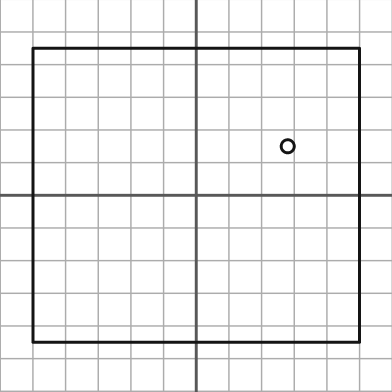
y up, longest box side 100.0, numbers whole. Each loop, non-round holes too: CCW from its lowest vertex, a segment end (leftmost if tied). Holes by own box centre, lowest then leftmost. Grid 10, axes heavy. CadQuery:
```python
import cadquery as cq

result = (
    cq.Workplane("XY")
    .moveTo(-50.0, -45.0)
    .lineTo(50.0, -45.0)
    .lineTo(50.0, 45.0)
    .lineTo(-50.0, 45.0)
    .close()
    .moveTo(28.0, 15.0)
    .circle(2.0)
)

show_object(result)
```